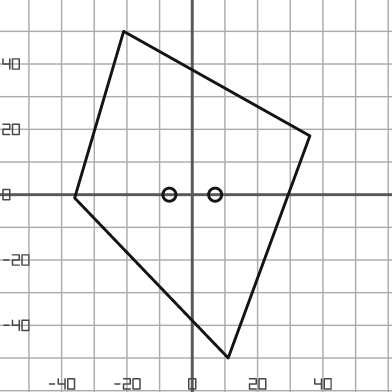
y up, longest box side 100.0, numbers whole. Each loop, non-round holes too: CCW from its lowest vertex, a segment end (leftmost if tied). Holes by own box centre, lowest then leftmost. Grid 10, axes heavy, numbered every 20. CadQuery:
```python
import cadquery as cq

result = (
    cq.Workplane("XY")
    .moveTo(11.0, -50.0)
    .lineTo(36.0, 18.0)
    .lineTo(-21.0, 50.0)
    .lineTo(-36.0, -1.0)
    .close()
    .moveTo(-7.0, 0.0)
    .circle(2.0)
    .moveTo(7.0, 0.0)
    .circle(2.0)
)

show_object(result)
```